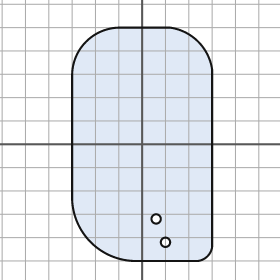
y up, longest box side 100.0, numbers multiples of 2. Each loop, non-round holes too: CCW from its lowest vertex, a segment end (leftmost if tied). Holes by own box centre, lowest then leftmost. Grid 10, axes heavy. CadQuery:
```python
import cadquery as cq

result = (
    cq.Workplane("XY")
    .moveTo(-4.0, -50.0)
    .lineTo(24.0, -50.0)
    .threePointArc((28.0, -48.0), (30.0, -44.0))
    .lineTo(30.0, 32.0)
    .threePointArc((24.0, 44.0), (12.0, 50.0))
    .lineTo(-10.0, 50.0)
    .threePointArc((-24.0, 44.0), (-30.0, 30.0))
    .lineTo(-30.0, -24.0)
    .threePointArc((-22.0, -42.0), (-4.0, -50.0))
    .close()
    .moveTo(10.0, -42.0)
    .circle(2.0)
    .moveTo(6.0, -32.0)
    .circle(2.0)
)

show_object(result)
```